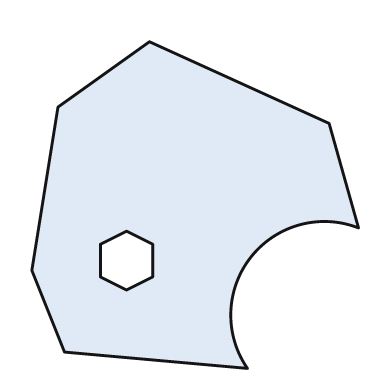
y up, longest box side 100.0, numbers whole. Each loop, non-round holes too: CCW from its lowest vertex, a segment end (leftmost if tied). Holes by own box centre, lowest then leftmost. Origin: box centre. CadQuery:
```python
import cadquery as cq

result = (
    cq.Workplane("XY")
    .moveTo(16.0, -50.0)
    .threePointArc((17.0, -16.0), (50.0, -7.0))
    .lineTo(41.0, 25.0)
    .lineTo(-14.0, 50.0)
    .lineTo(-42.0, 30.0)
    .lineTo(-50.0, -20.0)
    .lineTo(-40.0, -45.0)
    .close()
    .moveTo(-21.0, -26.0)
    .lineTo(-13.0, -22.0)
    .lineTo(-13.0, -12.0)
    .lineTo(-21.0, -8.0)
    .lineTo(-29.0, -12.0)
    .lineTo(-29.0, -22.0)
    .close()
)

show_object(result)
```